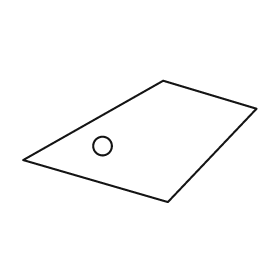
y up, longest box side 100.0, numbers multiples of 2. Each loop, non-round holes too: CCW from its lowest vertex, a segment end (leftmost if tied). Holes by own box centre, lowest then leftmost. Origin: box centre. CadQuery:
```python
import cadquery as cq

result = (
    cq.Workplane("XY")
    .moveTo(12.0, -26.0)
    .lineTo(50.0, 14.0)
    .lineTo(10.0, 26.0)
    .lineTo(-50.0, -8.0)
    .close()
    .moveTo(-16.0, -2.0)
    .circle(4.0)
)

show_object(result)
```